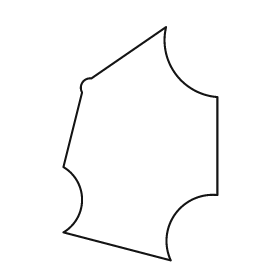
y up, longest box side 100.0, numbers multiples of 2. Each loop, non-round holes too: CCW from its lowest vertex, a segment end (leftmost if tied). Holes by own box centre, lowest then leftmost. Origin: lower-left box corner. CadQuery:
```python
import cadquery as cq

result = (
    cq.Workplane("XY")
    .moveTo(46.0, 0.0)
    .threePointArc((48.0, 20.0), (66.0, 28.0))
    .lineTo(66.0, 70.0)
    .threePointArc((48.0, 80.0), (44.0, 100.0))
    .lineTo(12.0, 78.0)
    .threePointArc((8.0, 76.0), (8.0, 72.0))
    .lineTo(0.0, 40.0)
    .threePointArc((8.0, 26.0), (0.0, 12.0))
    .close()
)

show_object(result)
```